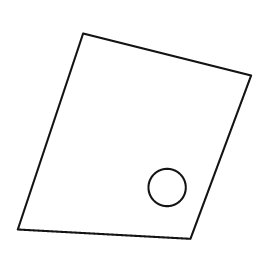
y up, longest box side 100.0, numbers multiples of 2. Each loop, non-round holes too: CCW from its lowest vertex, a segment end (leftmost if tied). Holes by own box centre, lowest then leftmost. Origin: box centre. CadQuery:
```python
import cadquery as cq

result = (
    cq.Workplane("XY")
    .moveTo(24.0, -44.0)
    .lineTo(50.0, 26.0)
    .lineTo(-22.0, 44.0)
    .lineTo(-50.0, -40.0)
    .close()
    .moveTo(14.0, -22.0)
    .circle(8.0)
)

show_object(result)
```